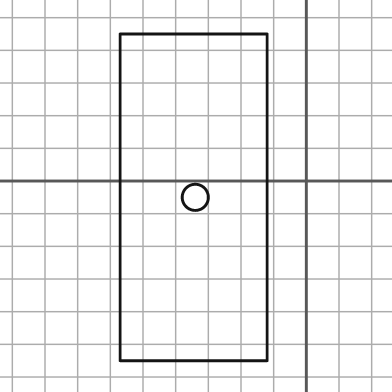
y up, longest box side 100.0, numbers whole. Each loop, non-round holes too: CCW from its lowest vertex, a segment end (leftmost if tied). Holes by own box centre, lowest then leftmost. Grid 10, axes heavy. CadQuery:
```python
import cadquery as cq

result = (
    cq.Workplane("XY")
    .moveTo(-57.0, -55.0)
    .lineTo(-12.0, -55.0)
    .lineTo(-12.0, 45.0)
    .lineTo(-57.0, 45.0)
    .close()
    .moveTo(-34.0, -5.0)
    .circle(4.0)
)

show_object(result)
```